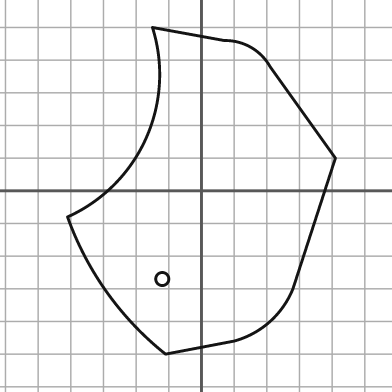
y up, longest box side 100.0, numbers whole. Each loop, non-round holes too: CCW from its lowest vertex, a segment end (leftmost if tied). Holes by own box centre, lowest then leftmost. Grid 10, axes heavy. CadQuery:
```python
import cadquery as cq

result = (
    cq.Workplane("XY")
    .moveTo(-11.0, -50.0)
    .lineTo(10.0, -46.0)
    .threePointArc((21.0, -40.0), (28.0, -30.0))
    .lineTo(41.0, 10.0)
    .lineTo(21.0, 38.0)
    .threePointArc((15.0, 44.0), (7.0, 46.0))
    .lineTo(-15.0, 50.0)
    .threePointArc((-17.0, 16.0), (-41.0, -8.0))
    .threePointArc((-29.0, -31.0), (-11.0, -50.0))
    .close()
    .moveTo(-12.0, -27.0)
    .circle(2.0)
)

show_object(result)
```